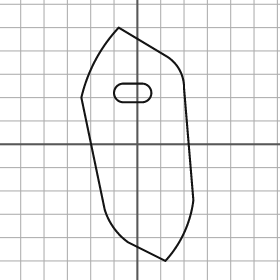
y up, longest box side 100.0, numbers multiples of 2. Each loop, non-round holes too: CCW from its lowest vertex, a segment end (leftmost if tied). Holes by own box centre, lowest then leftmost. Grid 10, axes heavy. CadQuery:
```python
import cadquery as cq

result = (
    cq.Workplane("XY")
    .moveTo(12.0, -50.0)
    .threePointArc((20.0, -38.0), (24.0, -24.0))
    .lineTo(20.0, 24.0)
    .threePointArc((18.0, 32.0), (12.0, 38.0))
    .lineTo(-8.0, 50.0)
    .threePointArc((-18.0, 36.0), (-24.0, 20.0))
    .lineTo(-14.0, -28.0)
    .threePointArc((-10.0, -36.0), (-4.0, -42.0))
    .close()
    .moveTo(-6.0, 18.0)
    .lineTo(2.0, 18.0)
    .threePointArc((6.0, 22.0), (2.0, 26.0))
    .lineTo(-6.0, 26.0)
    .threePointArc((-10.0, 22.0), (-6.0, 18.0))
    .close()
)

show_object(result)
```